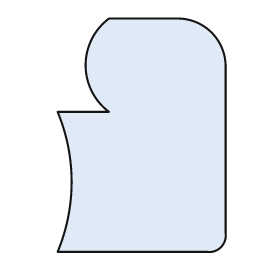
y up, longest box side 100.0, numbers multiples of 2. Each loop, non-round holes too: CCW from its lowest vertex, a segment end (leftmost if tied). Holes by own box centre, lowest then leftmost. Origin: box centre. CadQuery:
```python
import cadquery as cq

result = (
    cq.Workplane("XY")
    .moveTo(-36.0, -50.0)
    .lineTo(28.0, -50.0)
    .threePointArc((34.0, -48.0), (36.0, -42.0))
    .lineTo(36.0, 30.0)
    .threePointArc((30.0, 44.0), (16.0, 50.0))
    .lineTo(-14.0, 50.0)
    .threePointArc((-24.0, 30.0), (-14.0, 10.0))
    .lineTo(-36.0, 10.0)
    .threePointArc((-30.0, -20.0), (-36.0, -50.0))
    .close()
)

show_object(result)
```